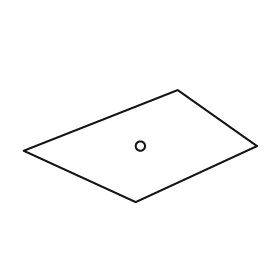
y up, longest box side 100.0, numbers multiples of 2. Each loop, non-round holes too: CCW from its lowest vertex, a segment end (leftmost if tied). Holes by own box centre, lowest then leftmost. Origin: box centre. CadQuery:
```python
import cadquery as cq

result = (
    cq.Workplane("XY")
    .moveTo(-2.0, -24.0)
    .lineTo(50.0, 0.0)
    .lineTo(16.0, 24.0)
    .lineTo(-50.0, -2.0)
    .close()
    .moveTo(0.0, 0.0)
    .circle(2.0)
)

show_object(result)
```